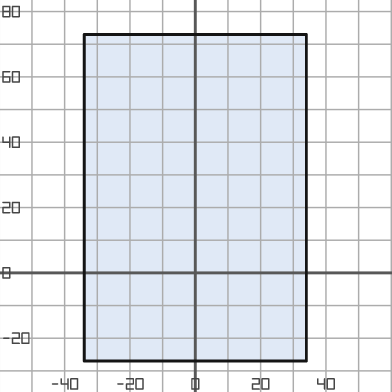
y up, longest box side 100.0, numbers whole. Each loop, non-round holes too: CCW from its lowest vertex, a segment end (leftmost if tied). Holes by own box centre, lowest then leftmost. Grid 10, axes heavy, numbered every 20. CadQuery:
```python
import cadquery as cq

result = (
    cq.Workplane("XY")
    .moveTo(-34.0, -27.0)
    .lineTo(34.0, -27.0)
    .lineTo(34.0, 73.0)
    .lineTo(-34.0, 73.0)
    .close()
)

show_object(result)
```